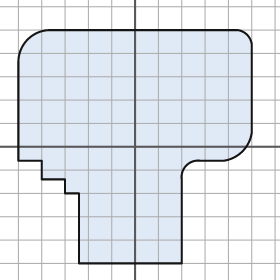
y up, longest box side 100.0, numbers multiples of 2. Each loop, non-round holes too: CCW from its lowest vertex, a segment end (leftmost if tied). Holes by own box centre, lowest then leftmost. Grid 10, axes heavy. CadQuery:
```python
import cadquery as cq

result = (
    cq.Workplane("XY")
    .moveTo(-24.0, -50.0)
    .lineTo(20.0, -50.0)
    .lineTo(20.0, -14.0)
    .threePointArc((22.0, -8.0), (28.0, -6.0))
    .lineTo(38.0, -6.0)
    .threePointArc((46.0, -2.0), (50.0, 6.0))
    .lineTo(50.0, 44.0)
    .threePointArc((48.0, 48.0), (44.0, 50.0))
    .lineTo(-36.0, 50.0)
    .threePointArc((-46.0, 46.0), (-50.0, 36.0))
    .lineTo(-50.0, -6.0)
    .lineTo(-40.0, -6.0)
    .lineTo(-40.0, -14.0)
    .lineTo(-30.0, -14.0)
    .lineTo(-30.0, -20.0)
    .lineTo(-24.0, -20.0)
    .close()
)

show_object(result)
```